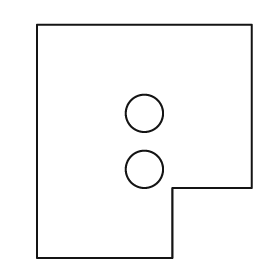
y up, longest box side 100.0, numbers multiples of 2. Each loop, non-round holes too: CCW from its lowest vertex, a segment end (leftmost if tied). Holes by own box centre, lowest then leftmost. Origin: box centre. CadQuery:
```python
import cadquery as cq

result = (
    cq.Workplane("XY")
    .moveTo(-46.0, -50.0)
    .lineTo(12.0, -50.0)
    .lineTo(12.0, -20.0)
    .lineTo(46.0, -20.0)
    .lineTo(46.0, 50.0)
    .lineTo(-46.0, 50.0)
    .close()
    .moveTo(0.0, -12.0)
    .circle(8.0)
    .moveTo(0.0, 12.0)
    .circle(8.0)
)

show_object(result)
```